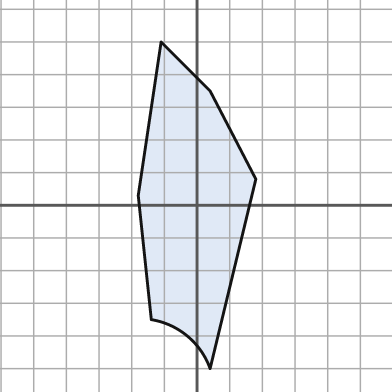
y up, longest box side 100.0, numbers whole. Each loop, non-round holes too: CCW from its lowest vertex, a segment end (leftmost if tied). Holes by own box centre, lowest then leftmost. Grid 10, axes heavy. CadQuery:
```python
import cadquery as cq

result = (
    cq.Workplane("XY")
    .moveTo(4.0, -50.0)
    .lineTo(18.0, 8.0)
    .lineTo(4.0, 35.0)
    .lineTo(-11.0, 50.0)
    .lineTo(-18.0, 3.0)
    .lineTo(-14.0, -35.0)
    .threePointArc((-3.0, -40.0), (4.0, -50.0))
    .close()
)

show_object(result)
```